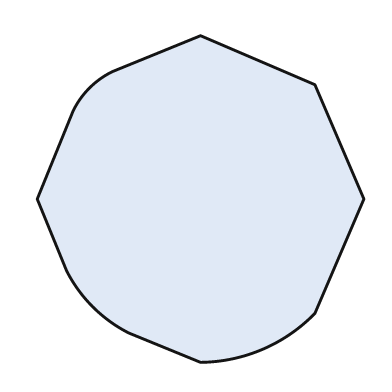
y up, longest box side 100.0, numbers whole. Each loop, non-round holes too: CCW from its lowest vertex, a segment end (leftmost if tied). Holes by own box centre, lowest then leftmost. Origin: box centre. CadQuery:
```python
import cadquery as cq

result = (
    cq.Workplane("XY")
    .moveTo(0.0, -50.0)
    .threePointArc((19.0, -46.0), (35.0, -35.0))
    .lineTo(50.0, 0.0)
    .lineTo(35.0, 35.0)
    .lineTo(0.0, 50.0)
    .lineTo(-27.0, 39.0)
    .threePointArc((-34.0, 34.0), (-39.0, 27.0))
    .lineTo(-50.0, 0.0)
    .lineTo(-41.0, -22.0)
    .threePointArc((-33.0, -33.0), (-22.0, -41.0))
    .close()
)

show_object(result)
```